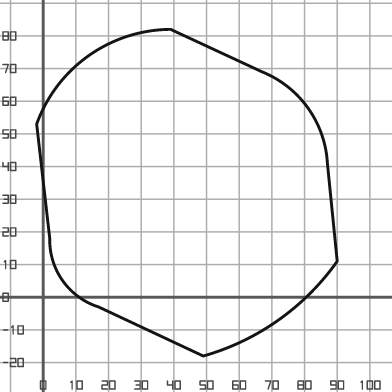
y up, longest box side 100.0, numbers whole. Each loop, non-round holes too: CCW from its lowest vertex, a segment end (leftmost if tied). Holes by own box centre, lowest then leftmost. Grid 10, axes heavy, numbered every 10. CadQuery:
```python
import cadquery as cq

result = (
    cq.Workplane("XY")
    .moveTo(49.0, -18.0)
    .threePointArc((72.0, -7.0), (90.0, 11.0))
    .lineTo(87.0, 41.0)
    .threePointArc((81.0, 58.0), (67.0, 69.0))
    .lineTo(39.0, 82.0)
    .threePointArc((14.0, 74.0), (-2.0, 53.0))
    .lineTo(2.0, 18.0)
    .threePointArc((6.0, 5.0), (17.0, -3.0))
    .close()
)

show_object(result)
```